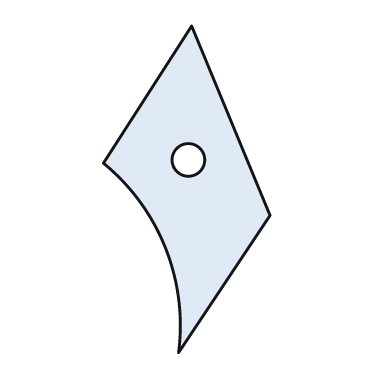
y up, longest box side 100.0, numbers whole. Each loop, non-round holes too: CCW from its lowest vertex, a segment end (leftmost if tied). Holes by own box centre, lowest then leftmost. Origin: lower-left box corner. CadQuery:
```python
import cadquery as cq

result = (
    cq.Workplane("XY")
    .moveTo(23.0, 0.0)
    .lineTo(51.0, 42.0)
    .lineTo(27.0, 100.0)
    .lineTo(0.0, 58.0)
    .threePointArc((19.0, 32.0), (23.0, 0.0))
    .close()
    .moveTo(26.0, 59.0)
    .circle(5.0)
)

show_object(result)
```